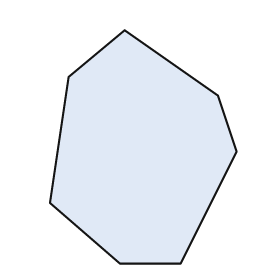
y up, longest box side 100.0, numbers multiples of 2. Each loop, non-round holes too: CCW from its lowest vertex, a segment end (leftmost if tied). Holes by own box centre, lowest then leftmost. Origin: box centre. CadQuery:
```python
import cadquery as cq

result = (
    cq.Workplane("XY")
    .moveTo(-10.0, -50.0)
    .lineTo(16.0, -50.0)
    .lineTo(40.0, -2.0)
    .lineTo(32.0, 22.0)
    .lineTo(-8.0, 50.0)
    .lineTo(-32.0, 30.0)
    .lineTo(-40.0, -24.0)
    .close()
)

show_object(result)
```